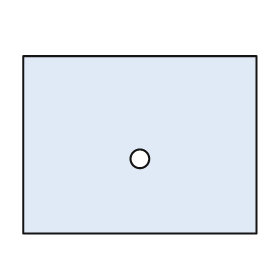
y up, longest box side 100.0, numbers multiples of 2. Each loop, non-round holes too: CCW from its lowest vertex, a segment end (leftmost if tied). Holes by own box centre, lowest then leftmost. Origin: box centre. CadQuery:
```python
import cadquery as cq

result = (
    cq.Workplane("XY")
    .moveTo(-50.0, -38.0)
    .lineTo(50.0, -38.0)
    .lineTo(50.0, 38.0)
    .lineTo(-50.0, 38.0)
    .close()
    .moveTo(0.0, -6.0)
    .circle(4.0)
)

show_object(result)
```